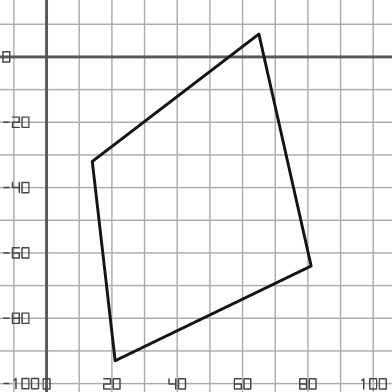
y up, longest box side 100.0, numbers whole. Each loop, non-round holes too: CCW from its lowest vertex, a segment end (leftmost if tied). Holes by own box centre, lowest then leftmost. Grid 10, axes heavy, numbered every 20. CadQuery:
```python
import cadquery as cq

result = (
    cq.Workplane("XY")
    .moveTo(21.0, -93.0)
    .lineTo(81.0, -64.0)
    .lineTo(65.0, 7.0)
    .lineTo(14.0, -32.0)
    .close()
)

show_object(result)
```